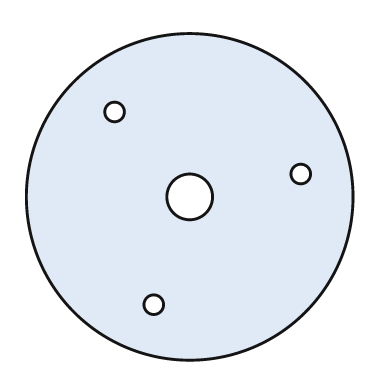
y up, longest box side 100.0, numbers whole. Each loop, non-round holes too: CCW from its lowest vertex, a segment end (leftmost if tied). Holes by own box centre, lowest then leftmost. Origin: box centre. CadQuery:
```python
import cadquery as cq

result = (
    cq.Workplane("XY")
    .moveTo(0.0, 0.0)
    .circle(50.0)
    .moveTo(-11.0, -33.0)
    .circle(3.0)
    .moveTo(0.0, 0.0)
    .circle(7.0)
    .moveTo(34.0, 7.0)
    .circle(3.0)
    .moveTo(-23.0, 26.0)
    .circle(3.0)
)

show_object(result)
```